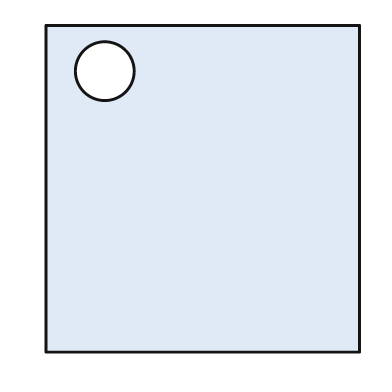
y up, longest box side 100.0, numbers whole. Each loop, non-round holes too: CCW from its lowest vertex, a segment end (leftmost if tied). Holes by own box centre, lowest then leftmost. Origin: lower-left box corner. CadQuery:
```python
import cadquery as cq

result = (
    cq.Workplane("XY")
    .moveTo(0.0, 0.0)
    .lineTo(96.0, 0.0)
    .lineTo(96.0, 100.0)
    .lineTo(0.0, 100.0)
    .close()
    .moveTo(18.0, 86.0)
    .circle(9.0)
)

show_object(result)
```